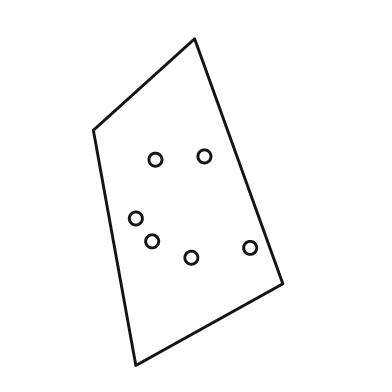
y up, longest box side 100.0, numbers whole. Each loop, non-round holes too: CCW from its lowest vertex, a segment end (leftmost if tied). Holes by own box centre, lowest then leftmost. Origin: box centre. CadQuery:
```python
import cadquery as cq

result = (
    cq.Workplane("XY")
    .moveTo(-16.0, -50.0)
    .lineTo(29.0, -25.0)
    .lineTo(2.0, 50.0)
    .lineTo(-29.0, 22.0)
    .close()
    .moveTo(1.0, -17.0)
    .circle(2.0)
    .moveTo(19.0, -14.0)
    .circle(2.0)
    .moveTo(-11.0, -12.0)
    .circle(2.0)
    .moveTo(-16.0, -5.0)
    .circle(2.0)
    .moveTo(-10.0, 13.0)
    .circle(2.0)
    .moveTo(5.0, 14.0)
    .circle(2.0)
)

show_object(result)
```